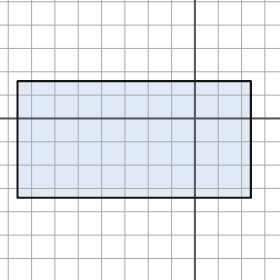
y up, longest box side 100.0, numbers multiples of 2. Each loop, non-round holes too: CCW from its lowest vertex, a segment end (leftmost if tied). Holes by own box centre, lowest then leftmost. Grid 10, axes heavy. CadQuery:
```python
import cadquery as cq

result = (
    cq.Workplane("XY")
    .moveTo(-76.0, -34.0)
    .lineTo(24.0, -34.0)
    .lineTo(24.0, 16.0)
    .lineTo(-76.0, 16.0)
    .close()
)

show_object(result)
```